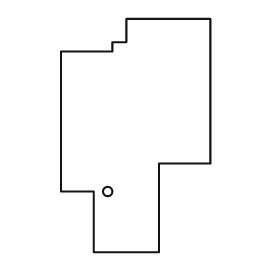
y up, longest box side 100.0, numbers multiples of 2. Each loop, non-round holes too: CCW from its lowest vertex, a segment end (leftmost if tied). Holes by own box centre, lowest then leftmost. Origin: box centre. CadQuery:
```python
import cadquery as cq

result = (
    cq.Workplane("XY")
    .moveTo(-18.0, -50.0)
    .lineTo(10.0, -50.0)
    .lineTo(10.0, -12.0)
    .lineTo(32.0, -12.0)
    .lineTo(32.0, 50.0)
    .lineTo(-4.0, 50.0)
    .lineTo(-4.0, 40.0)
    .lineTo(-10.0, 40.0)
    .lineTo(-10.0, 36.0)
    .lineTo(-32.0, 36.0)
    .lineTo(-32.0, -24.0)
    .lineTo(-18.0, -24.0)
    .close()
    .moveTo(-12.0, -24.0)
    .circle(2.0)
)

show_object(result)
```